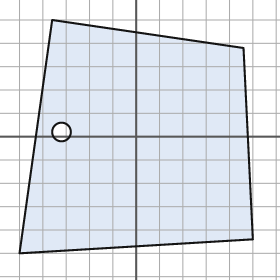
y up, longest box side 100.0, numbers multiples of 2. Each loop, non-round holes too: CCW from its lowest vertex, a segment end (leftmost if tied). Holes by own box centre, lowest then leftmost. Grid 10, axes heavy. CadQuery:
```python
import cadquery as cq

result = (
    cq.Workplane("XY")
    .moveTo(-50.0, -50.0)
    .lineTo(50.0, -44.0)
    .lineTo(46.0, 38.0)
    .lineTo(-36.0, 50.0)
    .close()
    .moveTo(-32.0, 2.0)
    .circle(4.0)
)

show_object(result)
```